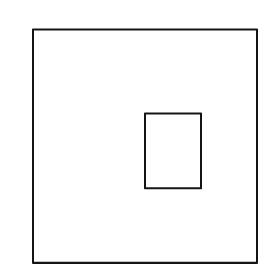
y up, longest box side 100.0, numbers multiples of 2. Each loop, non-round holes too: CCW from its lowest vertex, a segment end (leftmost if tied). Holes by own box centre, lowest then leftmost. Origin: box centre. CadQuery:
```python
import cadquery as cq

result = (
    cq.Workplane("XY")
    .moveTo(-48.0, -50.0)
    .lineTo(48.0, -50.0)
    .lineTo(48.0, 50.0)
    .lineTo(-48.0, 50.0)
    .close()
    .moveTo(0.0, -18.0)
    .lineTo(24.0, -18.0)
    .lineTo(24.0, 14.0)
    .lineTo(0.0, 14.0)
    .close()
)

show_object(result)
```